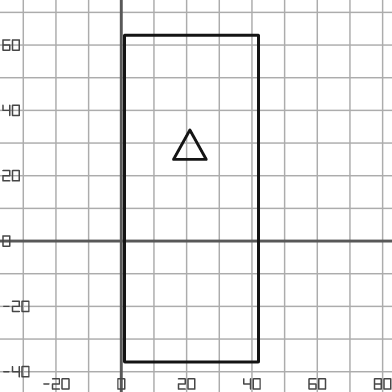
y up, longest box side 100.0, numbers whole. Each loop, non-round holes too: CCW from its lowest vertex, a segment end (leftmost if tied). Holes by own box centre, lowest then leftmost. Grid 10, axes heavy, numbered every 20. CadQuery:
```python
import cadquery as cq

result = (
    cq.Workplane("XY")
    .moveTo(1.0, -37.0)
    .lineTo(42.0, -37.0)
    .lineTo(42.0, 63.0)
    .lineTo(1.0, 63.0)
    .close()
    .moveTo(16.0, 25.0)
    .lineTo(26.0, 25.0)
    .lineTo(21.0, 34.0)
    .close()
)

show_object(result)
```